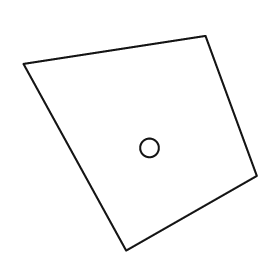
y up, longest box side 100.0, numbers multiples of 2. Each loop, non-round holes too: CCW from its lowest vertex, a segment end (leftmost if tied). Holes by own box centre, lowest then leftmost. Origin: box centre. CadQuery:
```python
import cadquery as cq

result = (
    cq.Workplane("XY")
    .moveTo(-6.0, -46.0)
    .lineTo(50.0, -14.0)
    .lineTo(28.0, 46.0)
    .lineTo(-50.0, 34.0)
    .close()
    .moveTo(4.0, -2.0)
    .circle(4.0)
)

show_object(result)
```